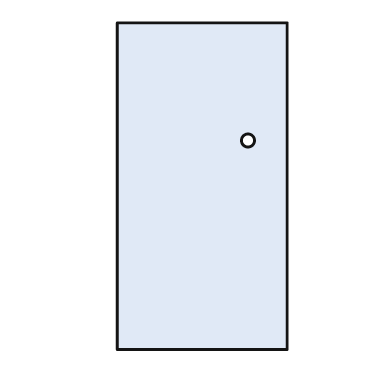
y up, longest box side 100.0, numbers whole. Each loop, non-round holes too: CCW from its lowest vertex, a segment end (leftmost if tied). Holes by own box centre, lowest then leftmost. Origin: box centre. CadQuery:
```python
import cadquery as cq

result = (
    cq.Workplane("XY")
    .moveTo(-26.0, -50.0)
    .lineTo(26.0, -50.0)
    .lineTo(26.0, 50.0)
    .lineTo(-26.0, 50.0)
    .close()
    .moveTo(14.0, 14.0)
    .circle(2.0)
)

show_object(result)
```